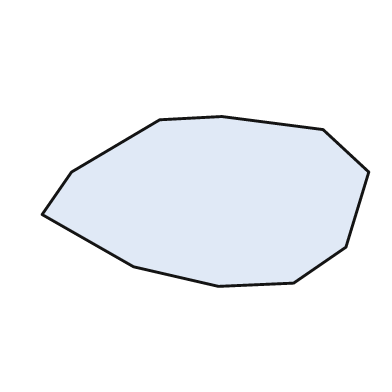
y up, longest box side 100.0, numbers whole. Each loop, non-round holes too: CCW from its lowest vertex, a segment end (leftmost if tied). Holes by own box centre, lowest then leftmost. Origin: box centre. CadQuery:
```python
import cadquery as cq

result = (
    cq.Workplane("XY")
    .moveTo(4.0, -26.0)
    .lineTo(27.0, -25.0)
    .lineTo(43.0, -14.0)
    .lineTo(50.0, 9.0)
    .lineTo(36.0, 22.0)
    .lineTo(5.0, 26.0)
    .lineTo(-14.0, 25.0)
    .lineTo(-41.0, 9.0)
    .lineTo(-50.0, -4.0)
    .lineTo(-22.0, -20.0)
    .close()
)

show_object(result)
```